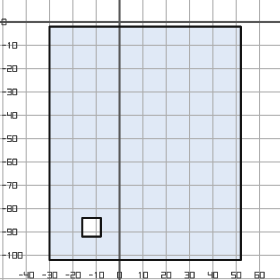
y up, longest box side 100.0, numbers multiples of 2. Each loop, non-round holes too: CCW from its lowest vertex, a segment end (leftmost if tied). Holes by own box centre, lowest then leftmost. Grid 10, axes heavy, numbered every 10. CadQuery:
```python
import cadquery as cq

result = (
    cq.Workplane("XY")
    .moveTo(-30.0, -102.0)
    .lineTo(52.0, -102.0)
    .lineTo(52.0, -2.0)
    .lineTo(-30.0, -2.0)
    .close()
    .moveTo(-16.0, -92.0)
    .lineTo(-8.0, -92.0)
    .lineTo(-8.0, -84.0)
    .lineTo(-16.0, -84.0)
    .close()
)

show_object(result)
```